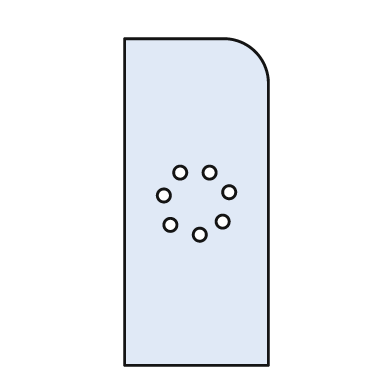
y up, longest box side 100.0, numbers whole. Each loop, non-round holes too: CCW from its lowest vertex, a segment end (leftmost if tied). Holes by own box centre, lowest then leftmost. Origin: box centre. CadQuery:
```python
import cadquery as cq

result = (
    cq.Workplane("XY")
    .moveTo(-22.0, -50.0)
    .lineTo(22.0, -50.0)
    .lineTo(22.0, 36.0)
    .threePointArc((18.0, 46.0), (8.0, 50.0))
    .lineTo(-22.0, 50.0)
    .close()
    .moveTo(1.0, -10.0)
    .circle(2.0)
    .moveTo(-8.0, -7.0)
    .circle(2.0)
    .moveTo(8.0, -6.0)
    .circle(2.0)
    .moveTo(-10.0, 2.0)
    .circle(2.0)
    .moveTo(10.0, 3.0)
    .circle(2.0)
    .moveTo(-5.0, 9.0)
    .circle(2.0)
    .moveTo(4.0, 9.0)
    .circle(2.0)
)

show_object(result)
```